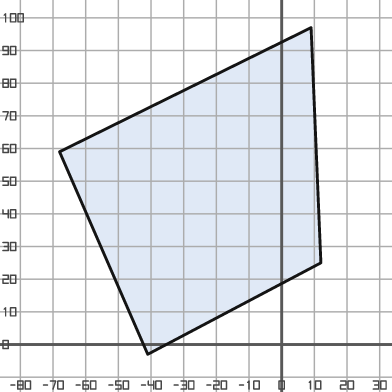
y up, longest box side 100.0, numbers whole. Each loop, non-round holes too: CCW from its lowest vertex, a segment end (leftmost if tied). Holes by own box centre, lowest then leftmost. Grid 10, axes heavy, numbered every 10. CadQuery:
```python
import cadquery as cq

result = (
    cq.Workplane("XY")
    .moveTo(-41.0, -3.0)
    .lineTo(12.0, 25.0)
    .lineTo(9.0, 97.0)
    .lineTo(-68.0, 59.0)
    .close()
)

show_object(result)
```